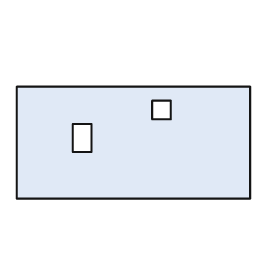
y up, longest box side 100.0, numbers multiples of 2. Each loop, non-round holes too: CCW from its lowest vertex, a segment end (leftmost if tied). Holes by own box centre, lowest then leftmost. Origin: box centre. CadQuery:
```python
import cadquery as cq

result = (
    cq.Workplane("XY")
    .moveTo(-50.0, -24.0)
    .lineTo(50.0, -24.0)
    .lineTo(50.0, 24.0)
    .lineTo(-50.0, 24.0)
    .close()
    .moveTo(-26.0, -4.0)
    .lineTo(-18.0, -4.0)
    .lineTo(-18.0, 8.0)
    .lineTo(-26.0, 8.0)
    .close()
    .moveTo(8.0, 10.0)
    .lineTo(16.0, 10.0)
    .lineTo(16.0, 18.0)
    .lineTo(8.0, 18.0)
    .close()
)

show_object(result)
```